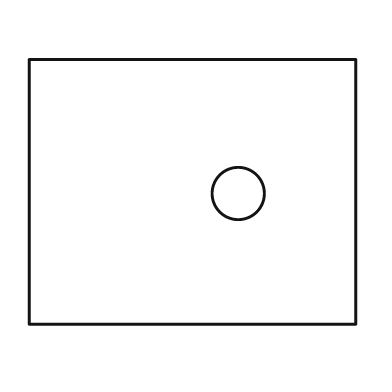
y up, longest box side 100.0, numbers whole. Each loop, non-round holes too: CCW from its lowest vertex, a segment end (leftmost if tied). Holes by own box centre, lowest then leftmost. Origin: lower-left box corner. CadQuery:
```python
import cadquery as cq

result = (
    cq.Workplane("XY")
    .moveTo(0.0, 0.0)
    .lineTo(100.0, 0.0)
    .lineTo(100.0, 81.0)
    .lineTo(0.0, 81.0)
    .close()
    .moveTo(64.0, 40.0)
    .circle(8.0)
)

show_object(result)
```